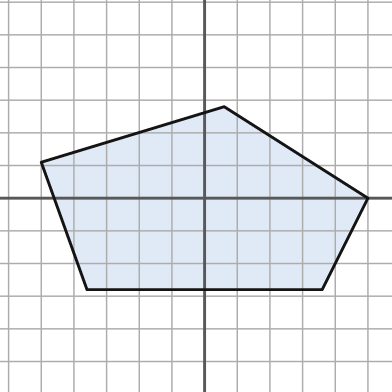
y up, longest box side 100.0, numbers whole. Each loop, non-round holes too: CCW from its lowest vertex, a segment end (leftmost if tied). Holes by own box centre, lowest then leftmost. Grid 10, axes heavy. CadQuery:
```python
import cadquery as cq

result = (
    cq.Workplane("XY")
    .moveTo(-36.0, -28.0)
    .lineTo(36.0, -28.0)
    .lineTo(50.0, 0.0)
    .lineTo(6.0, 28.0)
    .lineTo(-50.0, 11.0)
    .close()
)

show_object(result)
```